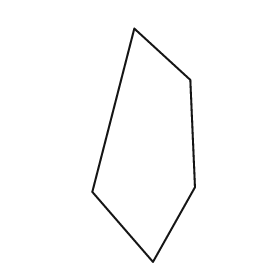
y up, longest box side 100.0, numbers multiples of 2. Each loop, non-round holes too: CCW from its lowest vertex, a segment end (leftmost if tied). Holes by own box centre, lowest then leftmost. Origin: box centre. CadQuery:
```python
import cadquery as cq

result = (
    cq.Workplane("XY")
    .moveTo(4.0, -50.0)
    .lineTo(22.0, -18.0)
    .lineTo(20.0, 28.0)
    .lineTo(-4.0, 50.0)
    .lineTo(-22.0, -20.0)
    .close()
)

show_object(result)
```